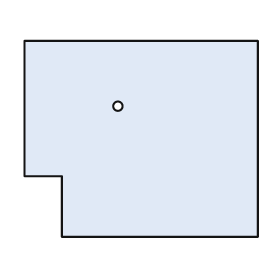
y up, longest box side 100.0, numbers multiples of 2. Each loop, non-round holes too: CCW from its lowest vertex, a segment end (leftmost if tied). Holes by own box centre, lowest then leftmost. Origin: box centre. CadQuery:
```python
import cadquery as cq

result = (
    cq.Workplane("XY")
    .moveTo(-34.0, -42.0)
    .lineTo(50.0, -42.0)
    .lineTo(50.0, 42.0)
    .lineTo(-50.0, 42.0)
    .lineTo(-50.0, -16.0)
    .lineTo(-34.0, -16.0)
    .close()
    .moveTo(-10.0, 14.0)
    .circle(2.0)
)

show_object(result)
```